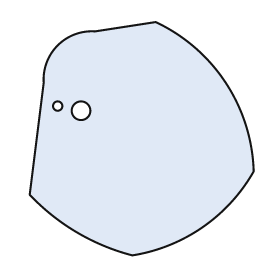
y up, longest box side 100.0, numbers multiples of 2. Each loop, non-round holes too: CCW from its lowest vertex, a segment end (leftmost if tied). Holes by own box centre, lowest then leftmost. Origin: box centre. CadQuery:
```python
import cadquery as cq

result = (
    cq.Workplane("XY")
    .moveTo(-4.0, -50.0)
    .threePointArc((26.0, -38.0), (48.0, -14.0))
    .threePointArc((36.0, 24.0), (6.0, 50.0))
    .lineTo(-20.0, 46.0)
    .threePointArc((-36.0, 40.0), (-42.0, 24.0))
    .lineTo(-48.0, -24.0)
    .threePointArc((-28.0, -40.0), (-4.0, -50.0))
    .close()
    .moveTo(-26.0, 12.0)
    .circle(4.0)
    .moveTo(-36.0, 14.0)
    .circle(2.0)
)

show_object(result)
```